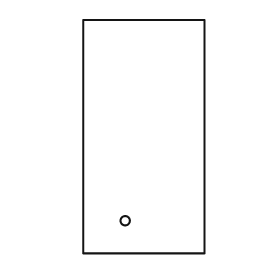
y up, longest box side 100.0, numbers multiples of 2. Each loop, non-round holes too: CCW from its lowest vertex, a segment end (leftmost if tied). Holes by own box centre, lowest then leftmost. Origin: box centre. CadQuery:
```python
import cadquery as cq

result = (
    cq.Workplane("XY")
    .moveTo(-26.0, -50.0)
    .lineTo(26.0, -50.0)
    .lineTo(26.0, 50.0)
    .lineTo(-26.0, 50.0)
    .close()
    .moveTo(-8.0, -36.0)
    .circle(2.0)
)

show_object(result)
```